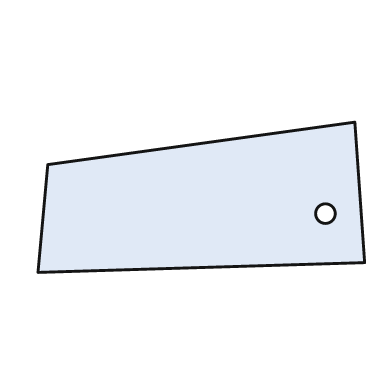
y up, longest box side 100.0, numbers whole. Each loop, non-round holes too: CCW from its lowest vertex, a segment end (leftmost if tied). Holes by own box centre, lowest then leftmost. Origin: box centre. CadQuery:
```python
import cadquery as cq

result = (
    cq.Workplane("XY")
    .moveTo(-50.0, -23.0)
    .lineTo(50.0, -20.0)
    .lineTo(47.0, 23.0)
    .lineTo(-47.0, 10.0)
    .close()
    .moveTo(38.0, -5.0)
    .circle(3.0)
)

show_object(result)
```